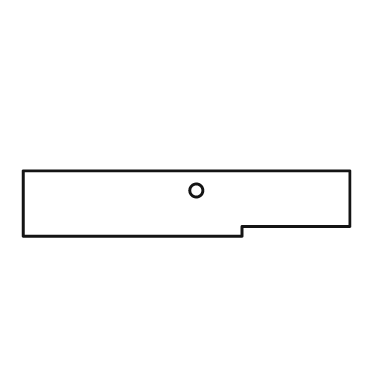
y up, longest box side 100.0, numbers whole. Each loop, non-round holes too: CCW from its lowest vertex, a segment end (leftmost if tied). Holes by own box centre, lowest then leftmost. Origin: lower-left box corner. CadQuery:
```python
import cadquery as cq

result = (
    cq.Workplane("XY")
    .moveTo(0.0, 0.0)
    .lineTo(67.0, 0.0)
    .lineTo(67.0, 3.0)
    .lineTo(100.0, 3.0)
    .lineTo(100.0, 20.0)
    .lineTo(0.0, 20.0)
    .close()
    .moveTo(53.0, 14.0)
    .circle(2.0)
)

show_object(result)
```